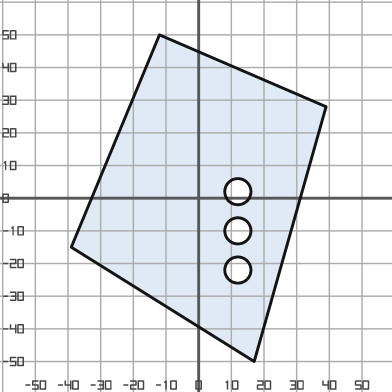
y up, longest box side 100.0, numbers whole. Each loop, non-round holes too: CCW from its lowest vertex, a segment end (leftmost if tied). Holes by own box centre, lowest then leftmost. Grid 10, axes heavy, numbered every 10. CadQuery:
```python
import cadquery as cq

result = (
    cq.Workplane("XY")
    .moveTo(17.0, -50.0)
    .lineTo(39.0, 28.0)
    .lineTo(-12.0, 50.0)
    .lineTo(-39.0, -15.0)
    .close()
    .moveTo(12.0, -22.0)
    .circle(4.0)
    .moveTo(12.0, -10.0)
    .circle(4.0)
    .moveTo(12.0, 2.0)
    .circle(4.0)
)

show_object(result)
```